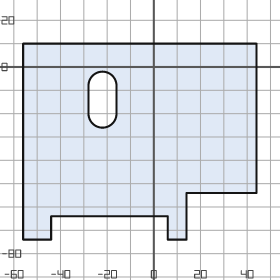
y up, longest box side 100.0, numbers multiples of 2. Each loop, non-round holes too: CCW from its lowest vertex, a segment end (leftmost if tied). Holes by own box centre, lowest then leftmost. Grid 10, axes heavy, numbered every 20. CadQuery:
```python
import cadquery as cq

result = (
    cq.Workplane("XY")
    .moveTo(-56.0, -74.0)
    .lineTo(-44.0, -74.0)
    .lineTo(-44.0, -64.0)
    .lineTo(6.0, -64.0)
    .lineTo(6.0, -74.0)
    .lineTo(14.0, -74.0)
    .lineTo(14.0, -54.0)
    .lineTo(44.0, -54.0)
    .lineTo(44.0, 10.0)
    .lineTo(-56.0, 10.0)
    .close()
    .moveTo(-28.0, -20.0)
    .threePointArc((-22.0, -26.0), (-16.0, -20.0))
    .lineTo(-16.0, -8.0)
    .threePointArc((-22.0, -2.0), (-28.0, -8.0))
    .close()
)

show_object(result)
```